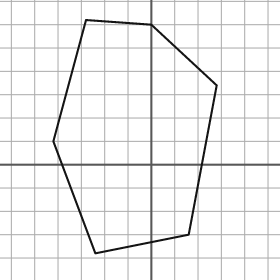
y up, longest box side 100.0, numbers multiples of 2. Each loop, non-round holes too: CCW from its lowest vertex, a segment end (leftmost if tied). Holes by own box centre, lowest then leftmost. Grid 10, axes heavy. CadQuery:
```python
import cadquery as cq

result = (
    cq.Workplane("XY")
    .moveTo(-24.0, -38.0)
    .lineTo(16.0, -30.0)
    .lineTo(28.0, 34.0)
    .lineTo(0.0, 60.0)
    .lineTo(-28.0, 62.0)
    .lineTo(-42.0, 10.0)
    .close()
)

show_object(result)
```